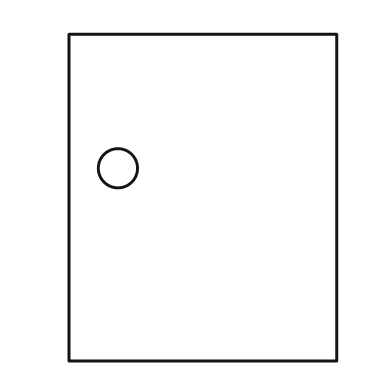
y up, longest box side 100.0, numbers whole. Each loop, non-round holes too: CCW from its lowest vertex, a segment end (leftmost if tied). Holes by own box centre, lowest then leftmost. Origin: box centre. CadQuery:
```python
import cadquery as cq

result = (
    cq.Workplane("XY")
    .moveTo(-41.0, -50.0)
    .lineTo(41.0, -50.0)
    .lineTo(41.0, 50.0)
    .lineTo(-41.0, 50.0)
    .close()
    .moveTo(-26.0, 9.0)
    .circle(6.0)
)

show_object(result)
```